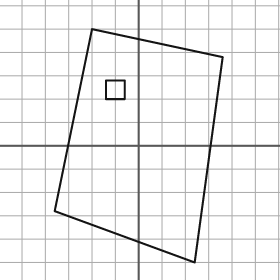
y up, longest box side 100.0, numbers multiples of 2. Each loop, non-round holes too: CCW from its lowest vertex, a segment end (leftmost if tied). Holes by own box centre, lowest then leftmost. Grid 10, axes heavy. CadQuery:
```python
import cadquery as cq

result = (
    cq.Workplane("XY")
    .moveTo(24.0, -50.0)
    .lineTo(36.0, 38.0)
    .lineTo(-20.0, 50.0)
    .lineTo(-36.0, -28.0)
    .close()
    .moveTo(-14.0, 20.0)
    .lineTo(-6.0, 20.0)
    .lineTo(-6.0, 28.0)
    .lineTo(-14.0, 28.0)
    .close()
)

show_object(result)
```